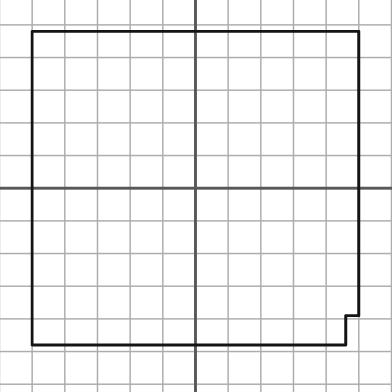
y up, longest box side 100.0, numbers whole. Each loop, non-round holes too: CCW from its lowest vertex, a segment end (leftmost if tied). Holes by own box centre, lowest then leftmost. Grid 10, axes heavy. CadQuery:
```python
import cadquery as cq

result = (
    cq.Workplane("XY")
    .moveTo(-50.0, -48.0)
    .lineTo(46.0, -48.0)
    .lineTo(46.0, -39.0)
    .lineTo(50.0, -39.0)
    .lineTo(50.0, 48.0)
    .lineTo(-50.0, 48.0)
    .close()
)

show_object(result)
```